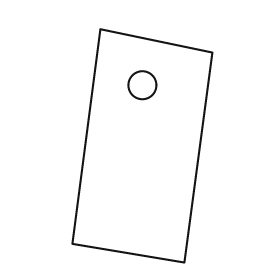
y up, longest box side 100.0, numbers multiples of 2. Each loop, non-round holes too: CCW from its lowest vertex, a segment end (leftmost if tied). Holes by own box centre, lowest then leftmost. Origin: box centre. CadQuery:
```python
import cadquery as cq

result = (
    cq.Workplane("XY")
    .moveTo(18.0, -50.0)
    .lineTo(30.0, 40.0)
    .lineTo(-18.0, 50.0)
    .lineTo(-30.0, -42.0)
    .close()
    .moveTo(0.0, 26.0)
    .circle(6.0)
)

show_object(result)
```